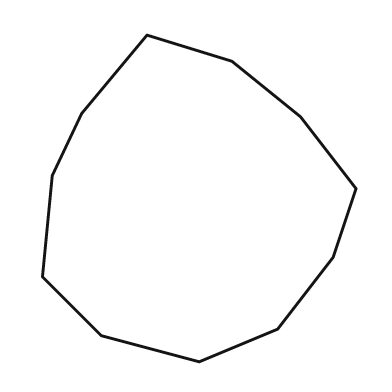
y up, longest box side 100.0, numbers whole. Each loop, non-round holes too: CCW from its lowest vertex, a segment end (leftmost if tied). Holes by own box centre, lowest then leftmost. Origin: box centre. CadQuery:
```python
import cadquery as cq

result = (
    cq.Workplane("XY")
    .moveTo(0.0, -50.0)
    .lineTo(24.0, -40.0)
    .lineTo(41.0, -18.0)
    .lineTo(48.0, 3.0)
    .lineTo(31.0, 25.0)
    .lineTo(10.0, 42.0)
    .lineTo(-16.0, 50.0)
    .lineTo(-36.0, 26.0)
    .lineTo(-45.0, 7.0)
    .lineTo(-48.0, -24.0)
    .lineTo(-30.0, -42.0)
    .close()
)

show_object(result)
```